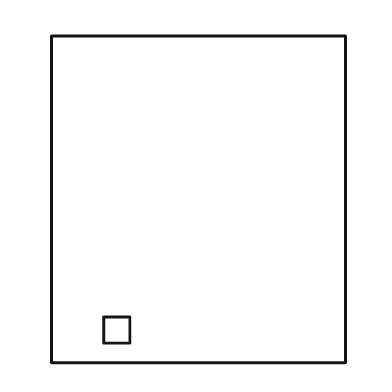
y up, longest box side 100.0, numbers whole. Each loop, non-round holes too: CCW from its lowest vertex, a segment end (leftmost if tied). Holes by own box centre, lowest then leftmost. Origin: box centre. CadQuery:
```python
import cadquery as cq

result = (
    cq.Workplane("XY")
    .moveTo(-45.0, -50.0)
    .lineTo(45.0, -50.0)
    .lineTo(45.0, 50.0)
    .lineTo(-45.0, 50.0)
    .close()
    .moveTo(-29.0, -44.0)
    .lineTo(-21.0, -44.0)
    .lineTo(-21.0, -36.0)
    .lineTo(-29.0, -36.0)
    .close()
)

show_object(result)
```